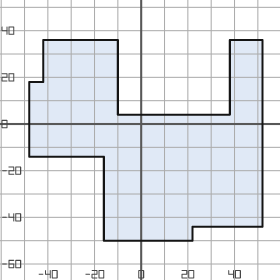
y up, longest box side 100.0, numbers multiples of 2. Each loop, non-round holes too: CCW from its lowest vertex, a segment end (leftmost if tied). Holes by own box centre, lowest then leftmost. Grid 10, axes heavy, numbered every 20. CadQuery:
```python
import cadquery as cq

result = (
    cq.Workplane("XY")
    .moveTo(-16.0, -50.0)
    .lineTo(22.0, -50.0)
    .lineTo(22.0, -44.0)
    .lineTo(52.0, -44.0)
    .lineTo(52.0, 36.0)
    .lineTo(38.0, 36.0)
    .lineTo(38.0, 4.0)
    .lineTo(-10.0, 4.0)
    .lineTo(-10.0, 36.0)
    .lineTo(-42.0, 36.0)
    .lineTo(-42.0, 18.0)
    .lineTo(-48.0, 18.0)
    .lineTo(-48.0, -14.0)
    .lineTo(-16.0, -14.0)
    .close()
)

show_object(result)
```